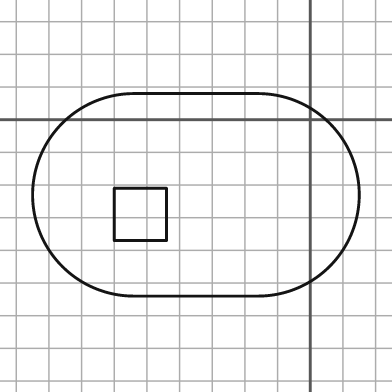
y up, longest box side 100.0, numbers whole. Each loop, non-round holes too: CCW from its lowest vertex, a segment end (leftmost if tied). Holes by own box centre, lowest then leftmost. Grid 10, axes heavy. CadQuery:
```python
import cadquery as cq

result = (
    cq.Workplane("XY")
    .moveTo(-54.0, -54.0)
    .lineTo(-16.0, -54.0)
    .threePointArc((15.0, -23.0), (-16.0, 8.0))
    .lineTo(-54.0, 8.0)
    .threePointArc((-85.0, -23.0), (-54.0, -54.0))
    .close()
    .moveTo(-60.0, -37.0)
    .lineTo(-44.0, -37.0)
    .lineTo(-44.0, -21.0)
    .lineTo(-60.0, -21.0)
    .close()
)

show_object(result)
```